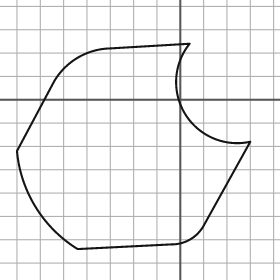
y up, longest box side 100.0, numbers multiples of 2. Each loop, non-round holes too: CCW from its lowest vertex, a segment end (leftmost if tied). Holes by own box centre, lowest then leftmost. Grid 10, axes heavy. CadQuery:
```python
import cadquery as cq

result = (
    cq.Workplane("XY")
    .moveTo(-44.0, -64.0)
    .lineTo(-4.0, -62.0)
    .threePointArc((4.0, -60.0), (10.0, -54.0))
    .lineTo(30.0, -18.0)
    .threePointArc((2.0, -6.0), (4.0, 24.0))
    .lineTo(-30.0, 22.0)
    .threePointArc((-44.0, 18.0), (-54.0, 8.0))
    .lineTo(-70.0, -22.0)
    .threePointArc((-62.0, -46.0), (-44.0, -64.0))
    .close()
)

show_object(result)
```